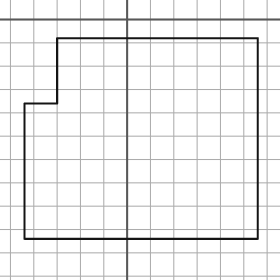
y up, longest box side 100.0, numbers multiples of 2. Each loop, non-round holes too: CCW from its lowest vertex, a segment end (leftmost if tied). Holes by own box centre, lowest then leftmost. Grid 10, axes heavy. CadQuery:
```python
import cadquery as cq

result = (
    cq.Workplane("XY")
    .moveTo(-44.0, -94.0)
    .lineTo(56.0, -94.0)
    .lineTo(56.0, -8.0)
    .lineTo(-30.0, -8.0)
    .lineTo(-30.0, -36.0)
    .lineTo(-44.0, -36.0)
    .close()
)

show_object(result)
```